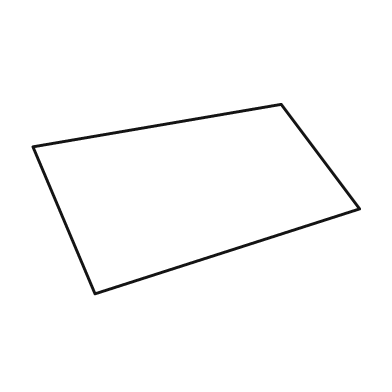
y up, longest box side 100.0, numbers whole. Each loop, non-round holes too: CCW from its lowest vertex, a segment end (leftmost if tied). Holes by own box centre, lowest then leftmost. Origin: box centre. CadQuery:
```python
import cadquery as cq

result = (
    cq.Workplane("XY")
    .moveTo(-31.0, -29.0)
    .lineTo(50.0, -3.0)
    .lineTo(26.0, 29.0)
    .lineTo(-50.0, 16.0)
    .close()
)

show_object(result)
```